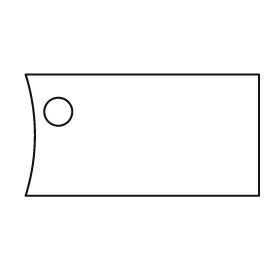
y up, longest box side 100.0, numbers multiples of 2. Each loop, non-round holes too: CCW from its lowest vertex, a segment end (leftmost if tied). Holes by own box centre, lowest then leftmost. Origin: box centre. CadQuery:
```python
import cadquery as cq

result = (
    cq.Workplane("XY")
    .moveTo(-50.0, -26.0)
    .lineTo(50.0, -26.0)
    .lineTo(50.0, 26.0)
    .lineTo(-50.0, 26.0)
    .threePointArc((-46.0, 0.0), (-50.0, -26.0))
    .close()
    .moveTo(-36.0, 10.0)
    .circle(6.0)
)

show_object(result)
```